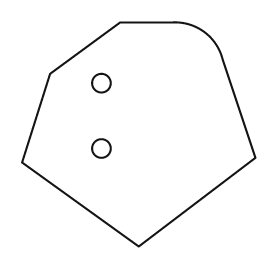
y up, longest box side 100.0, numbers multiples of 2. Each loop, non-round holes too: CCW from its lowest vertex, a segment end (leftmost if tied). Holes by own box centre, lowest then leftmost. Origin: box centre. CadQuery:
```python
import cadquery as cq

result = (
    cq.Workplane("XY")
    .moveTo(0.0, -48.0)
    .lineTo(50.0, -10.0)
    .lineTo(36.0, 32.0)
    .threePointArc((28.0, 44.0), (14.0, 48.0))
    .lineTo(-8.0, 48.0)
    .lineTo(-38.0, 26.0)
    .lineTo(-50.0, -12.0)
    .close()
    .moveTo(-16.0, -6.0)
    .circle(4.0)
    .moveTo(-16.0, 22.0)
    .circle(4.0)
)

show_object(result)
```